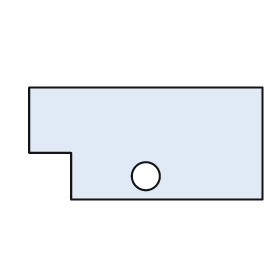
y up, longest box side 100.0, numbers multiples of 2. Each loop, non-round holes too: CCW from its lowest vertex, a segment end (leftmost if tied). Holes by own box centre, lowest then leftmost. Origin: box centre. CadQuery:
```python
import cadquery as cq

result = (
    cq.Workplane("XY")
    .moveTo(-32.0, -24.0)
    .lineTo(50.0, -24.0)
    .lineTo(50.0, 24.0)
    .lineTo(-50.0, 24.0)
    .lineTo(-50.0, -4.0)
    .lineTo(-32.0, -4.0)
    .close()
    .moveTo(0.0, -14.0)
    .circle(6.0)
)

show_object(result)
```